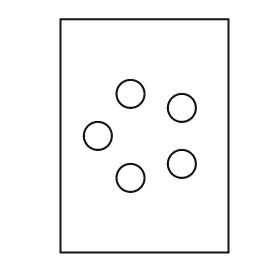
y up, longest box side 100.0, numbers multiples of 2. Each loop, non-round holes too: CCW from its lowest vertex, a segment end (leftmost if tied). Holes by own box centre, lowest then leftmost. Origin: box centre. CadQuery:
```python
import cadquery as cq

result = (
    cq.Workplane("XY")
    .moveTo(-36.0, -50.0)
    .lineTo(36.0, -50.0)
    .lineTo(36.0, 50.0)
    .lineTo(-36.0, 50.0)
    .close()
    .moveTo(-6.0, -18.0)
    .circle(6.0)
    .moveTo(16.0, -12.0)
    .circle(6.0)
    .moveTo(-20.0, 0.0)
    .circle(6.0)
    .moveTo(16.0, 12.0)
    .circle(6.0)
    .moveTo(-6.0, 18.0)
    .circle(6.0)
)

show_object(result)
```